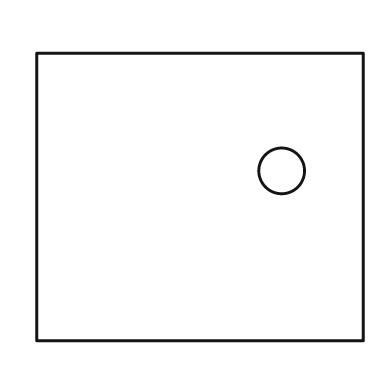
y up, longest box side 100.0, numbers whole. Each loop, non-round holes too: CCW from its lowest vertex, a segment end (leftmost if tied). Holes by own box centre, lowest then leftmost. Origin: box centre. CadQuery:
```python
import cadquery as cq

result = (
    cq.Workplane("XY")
    .moveTo(-50.0, -44.0)
    .lineTo(50.0, -44.0)
    .lineTo(50.0, 44.0)
    .lineTo(-50.0, 44.0)
    .close()
    .moveTo(25.0, 8.0)
    .circle(7.0)
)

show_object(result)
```